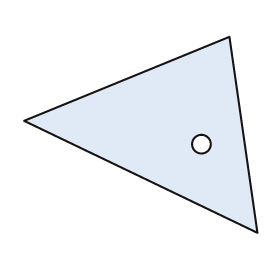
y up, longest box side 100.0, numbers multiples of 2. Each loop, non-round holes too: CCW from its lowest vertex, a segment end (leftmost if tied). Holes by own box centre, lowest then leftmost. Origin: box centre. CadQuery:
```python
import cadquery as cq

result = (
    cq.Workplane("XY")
    .moveTo(50.0, -42.0)
    .lineTo(38.0, 42.0)
    .lineTo(-50.0, 6.0)
    .close()
    .moveTo(26.0, -4.0)
    .circle(4.0)
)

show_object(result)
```